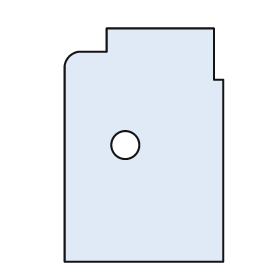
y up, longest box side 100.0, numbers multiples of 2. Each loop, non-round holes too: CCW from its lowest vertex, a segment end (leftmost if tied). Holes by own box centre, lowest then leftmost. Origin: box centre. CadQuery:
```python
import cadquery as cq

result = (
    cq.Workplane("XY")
    .moveTo(-34.0, -50.0)
    .lineTo(34.0, -50.0)
    .lineTo(34.0, 28.0)
    .lineTo(30.0, 28.0)
    .lineTo(30.0, 50.0)
    .lineTo(-16.0, 50.0)
    .lineTo(-16.0, 40.0)
    .lineTo(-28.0, 40.0)
    .threePointArc((-32.0, 38.0), (-34.0, 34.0))
    .close()
    .moveTo(-8.0, 0.0)
    .circle(6.0)
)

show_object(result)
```